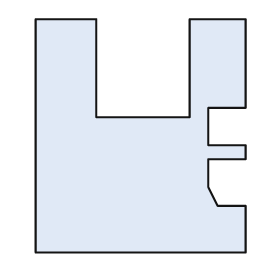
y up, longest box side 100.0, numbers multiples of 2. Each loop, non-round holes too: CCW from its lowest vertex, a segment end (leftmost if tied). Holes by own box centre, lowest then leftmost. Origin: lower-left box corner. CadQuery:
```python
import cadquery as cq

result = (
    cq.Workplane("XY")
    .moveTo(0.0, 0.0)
    .lineTo(90.0, 0.0)
    .lineTo(90.0, 20.0)
    .lineTo(78.0, 20.0)
    .lineTo(74.0, 28.0)
    .lineTo(74.0, 40.0)
    .lineTo(90.0, 40.0)
    .lineTo(90.0, 46.0)
    .lineTo(74.0, 46.0)
    .lineTo(74.0, 62.0)
    .lineTo(90.0, 62.0)
    .lineTo(90.0, 100.0)
    .lineTo(66.0, 100.0)
    .lineTo(66.0, 58.0)
    .lineTo(26.0, 58.0)
    .lineTo(26.0, 100.0)
    .lineTo(0.0, 100.0)
    .close()
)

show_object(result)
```